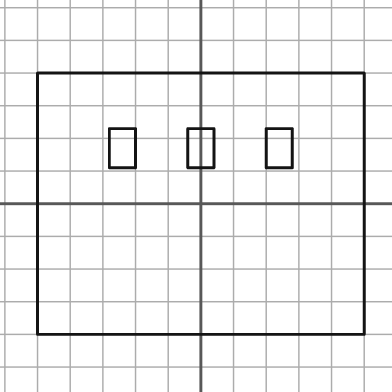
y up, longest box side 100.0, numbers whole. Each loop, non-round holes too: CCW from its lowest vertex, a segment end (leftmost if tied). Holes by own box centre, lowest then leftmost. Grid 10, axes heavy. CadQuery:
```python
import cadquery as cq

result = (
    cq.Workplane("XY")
    .moveTo(-50.0, -40.0)
    .lineTo(50.0, -40.0)
    .lineTo(50.0, 40.0)
    .lineTo(-50.0, 40.0)
    .close()
    .moveTo(-28.0, 11.0)
    .lineTo(-20.0, 11.0)
    .lineTo(-20.0, 23.0)
    .lineTo(-28.0, 23.0)
    .close()
    .moveTo(-4.0, 11.0)
    .lineTo(4.0, 11.0)
    .lineTo(4.0, 23.0)
    .lineTo(-4.0, 23.0)
    .close()
    .moveTo(20.0, 11.0)
    .lineTo(28.0, 11.0)
    .lineTo(28.0, 23.0)
    .lineTo(20.0, 23.0)
    .close()
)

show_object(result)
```